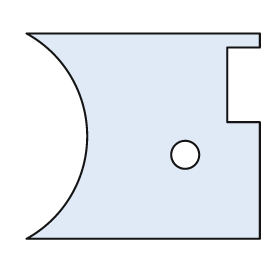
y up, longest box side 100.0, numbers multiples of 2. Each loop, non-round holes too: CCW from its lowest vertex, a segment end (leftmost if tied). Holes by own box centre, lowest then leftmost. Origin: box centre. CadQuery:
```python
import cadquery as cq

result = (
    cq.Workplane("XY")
    .moveTo(-50.0, -44.0)
    .lineTo(50.0, -44.0)
    .lineTo(50.0, 6.0)
    .lineTo(36.0, 6.0)
    .lineTo(36.0, 38.0)
    .lineTo(50.0, 38.0)
    .lineTo(50.0, 44.0)
    .lineTo(-50.0, 44.0)
    .threePointArc((-24.0, 0.0), (-50.0, -44.0))
    .close()
    .moveTo(18.0, -8.0)
    .circle(6.0)
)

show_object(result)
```